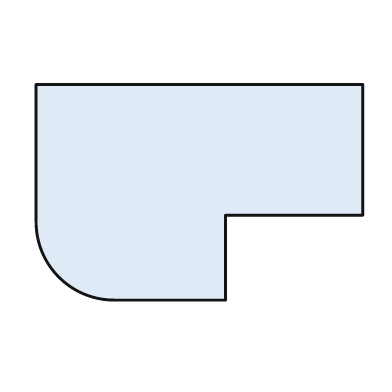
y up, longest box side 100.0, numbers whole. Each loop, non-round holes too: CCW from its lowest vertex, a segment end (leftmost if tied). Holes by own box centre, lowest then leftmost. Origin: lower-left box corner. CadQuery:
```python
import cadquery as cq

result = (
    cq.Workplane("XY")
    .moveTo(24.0, 0.0)
    .lineTo(58.0, 0.0)
    .lineTo(58.0, 26.0)
    .lineTo(100.0, 26.0)
    .lineTo(100.0, 66.0)
    .lineTo(0.0, 66.0)
    .lineTo(0.0, 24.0)
    .threePointArc((7.0, 7.0), (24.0, 0.0))
    .close()
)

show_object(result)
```